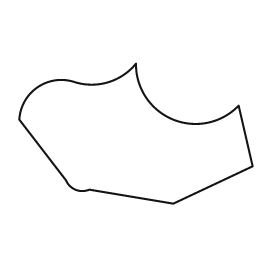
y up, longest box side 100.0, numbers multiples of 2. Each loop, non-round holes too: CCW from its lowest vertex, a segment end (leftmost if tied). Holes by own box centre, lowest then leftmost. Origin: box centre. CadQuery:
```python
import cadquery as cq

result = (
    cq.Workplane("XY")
    .moveTo(16.0, -30.0)
    .lineTo(50.0, -14.0)
    .lineTo(44.0, 12.0)
    .threePointArc((16.0, 6.0), (0.0, 30.0))
    .threePointArc((-12.0, 22.0), (-26.0, 22.0))
    .threePointArc((-42.0, 20.0), (-50.0, 6.0))
    .lineTo(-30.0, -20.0)
    .threePointArc((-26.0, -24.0), (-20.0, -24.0))
    .close()
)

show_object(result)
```